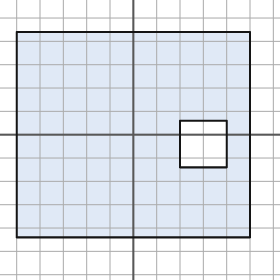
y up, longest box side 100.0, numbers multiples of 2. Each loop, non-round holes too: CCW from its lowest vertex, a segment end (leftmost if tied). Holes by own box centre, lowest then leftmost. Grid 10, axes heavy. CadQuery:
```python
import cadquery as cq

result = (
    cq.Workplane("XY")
    .moveTo(-50.0, -44.0)
    .lineTo(50.0, -44.0)
    .lineTo(50.0, 44.0)
    .lineTo(-50.0, 44.0)
    .close()
    .moveTo(20.0, -14.0)
    .lineTo(40.0, -14.0)
    .lineTo(40.0, 6.0)
    .lineTo(20.0, 6.0)
    .close()
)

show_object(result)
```